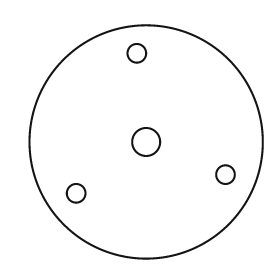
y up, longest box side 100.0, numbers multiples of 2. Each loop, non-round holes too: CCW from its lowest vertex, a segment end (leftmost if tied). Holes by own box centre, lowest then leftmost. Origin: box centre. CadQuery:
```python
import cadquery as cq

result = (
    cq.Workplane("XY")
    .moveTo(0.0, 0.0)
    .circle(50.0)
    .moveTo(-30.0, -22.0)
    .circle(4.0)
    .moveTo(34.0, -14.0)
    .circle(4.0)
    .moveTo(0.0, 0.0)
    .circle(6.0)
    .moveTo(-4.0, 38.0)
    .circle(4.0)
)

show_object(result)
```